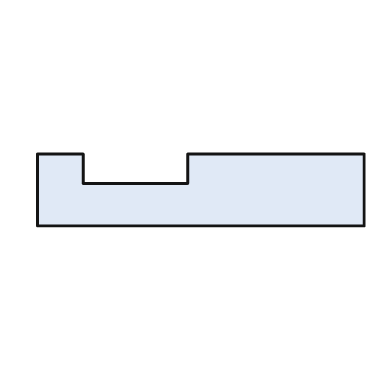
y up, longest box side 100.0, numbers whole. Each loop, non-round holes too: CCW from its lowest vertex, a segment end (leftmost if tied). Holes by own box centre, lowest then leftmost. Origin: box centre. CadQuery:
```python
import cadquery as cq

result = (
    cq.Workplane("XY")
    .moveTo(-50.0, -11.0)
    .lineTo(50.0, -11.0)
    .lineTo(50.0, 11.0)
    .lineTo(-4.0, 11.0)
    .lineTo(-4.0, 2.0)
    .lineTo(-36.0, 2.0)
    .lineTo(-36.0, 11.0)
    .lineTo(-50.0, 11.0)
    .close()
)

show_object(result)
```